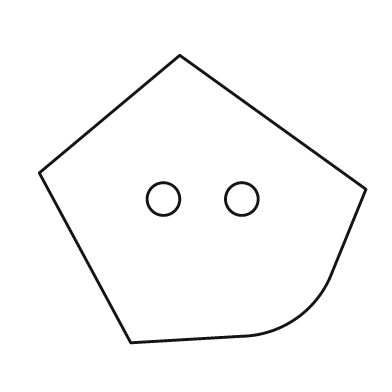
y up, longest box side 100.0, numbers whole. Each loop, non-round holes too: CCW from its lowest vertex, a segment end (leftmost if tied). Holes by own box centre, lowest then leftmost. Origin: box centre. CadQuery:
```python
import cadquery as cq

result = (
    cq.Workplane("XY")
    .moveTo(-22.0, -44.0)
    .lineTo(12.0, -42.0)
    .threePointArc((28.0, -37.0), (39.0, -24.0))
    .lineTo(50.0, 3.0)
    .lineTo(-7.0, 44.0)
    .lineTo(-50.0, 8.0)
    .close()
    .moveTo(-12.0, 0.0)
    .circle(5.0)
    .moveTo(12.0, 0.0)
    .circle(5.0)
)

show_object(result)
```